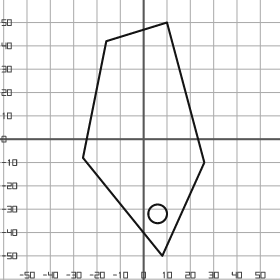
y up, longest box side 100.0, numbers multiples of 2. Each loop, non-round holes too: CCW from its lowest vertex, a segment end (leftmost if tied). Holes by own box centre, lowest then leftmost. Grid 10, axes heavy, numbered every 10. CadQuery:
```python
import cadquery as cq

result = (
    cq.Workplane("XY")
    .moveTo(8.0, -50.0)
    .lineTo(26.0, -10.0)
    .lineTo(10.0, 50.0)
    .lineTo(-16.0, 42.0)
    .lineTo(-26.0, -8.0)
    .close()
    .moveTo(6.0, -32.0)
    .circle(4.0)
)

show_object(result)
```